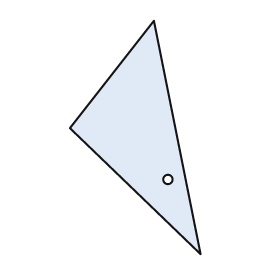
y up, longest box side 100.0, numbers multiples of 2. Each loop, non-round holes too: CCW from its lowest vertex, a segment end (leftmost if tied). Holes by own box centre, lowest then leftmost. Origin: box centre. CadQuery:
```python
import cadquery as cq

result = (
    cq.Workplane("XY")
    .moveTo(28.0, -50.0)
    .lineTo(8.0, 50.0)
    .lineTo(-28.0, 4.0)
    .close()
    .moveTo(14.0, -18.0)
    .circle(2.0)
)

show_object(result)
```